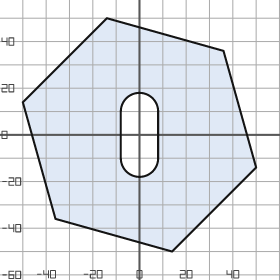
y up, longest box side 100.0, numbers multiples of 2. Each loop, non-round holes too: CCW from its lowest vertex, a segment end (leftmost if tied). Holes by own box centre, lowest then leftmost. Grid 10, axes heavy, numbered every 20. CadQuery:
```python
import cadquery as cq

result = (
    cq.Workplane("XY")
    .moveTo(14.0, -50.0)
    .lineTo(50.0, -14.0)
    .lineTo(36.0, 36.0)
    .lineTo(-14.0, 50.0)
    .lineTo(-50.0, 14.0)
    .lineTo(-36.0, -36.0)
    .close()
    .moveTo(-8.0, -10.0)
    .threePointArc((0.0, -18.0), (8.0, -10.0))
    .lineTo(8.0, 10.0)
    .threePointArc((0.0, 18.0), (-8.0, 10.0))
    .close()
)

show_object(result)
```